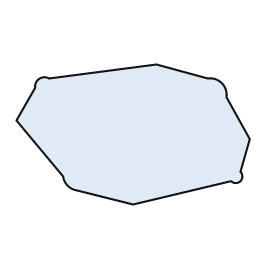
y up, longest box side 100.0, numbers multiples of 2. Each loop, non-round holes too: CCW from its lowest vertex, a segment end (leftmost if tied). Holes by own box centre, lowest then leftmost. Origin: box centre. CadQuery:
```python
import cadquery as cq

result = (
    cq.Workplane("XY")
    .moveTo(0.0, -30.0)
    .lineTo(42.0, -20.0)
    .threePointArc((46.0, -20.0), (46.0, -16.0))
    .lineTo(50.0, -2.0)
    .lineTo(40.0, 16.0)
    .threePointArc((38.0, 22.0), (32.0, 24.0))
    .lineTo(10.0, 30.0)
    .lineTo(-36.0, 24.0)
    .threePointArc((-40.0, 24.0), (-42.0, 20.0))
    .lineTo(-50.0, 6.0)
    .lineTo(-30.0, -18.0)
    .threePointArc((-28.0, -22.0), (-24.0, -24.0))
    .close()
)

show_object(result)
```